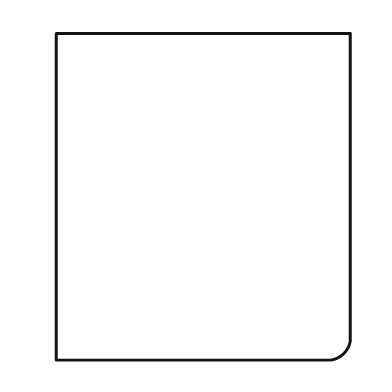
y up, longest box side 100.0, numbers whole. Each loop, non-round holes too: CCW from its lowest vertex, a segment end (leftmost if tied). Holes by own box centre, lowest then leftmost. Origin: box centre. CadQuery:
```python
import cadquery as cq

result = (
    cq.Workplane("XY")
    .moveTo(-45.0, -50.0)
    .lineTo(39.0, -50.0)
    .threePointArc((43.0, -48.0), (45.0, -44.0))
    .lineTo(45.0, 50.0)
    .lineTo(-45.0, 50.0)
    .close()
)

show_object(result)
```